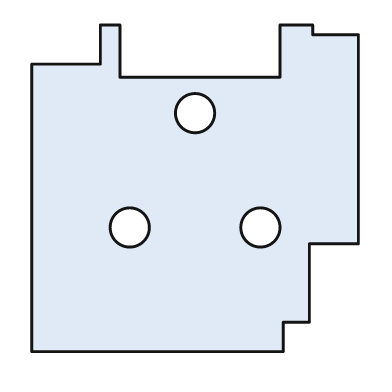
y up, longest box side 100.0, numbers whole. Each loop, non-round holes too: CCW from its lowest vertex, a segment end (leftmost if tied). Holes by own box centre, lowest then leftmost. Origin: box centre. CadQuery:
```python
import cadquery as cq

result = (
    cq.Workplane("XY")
    .moveTo(-50.0, -50.0)
    .lineTo(27.0, -50.0)
    .lineTo(27.0, -41.0)
    .lineTo(35.0, -41.0)
    .lineTo(35.0, -17.0)
    .lineTo(50.0, -17.0)
    .lineTo(50.0, 47.0)
    .lineTo(36.0, 47.0)
    .lineTo(36.0, 50.0)
    .lineTo(26.0, 50.0)
    .lineTo(26.0, 34.0)
    .lineTo(-23.0, 34.0)
    .lineTo(-23.0, 50.0)
    .lineTo(-29.0, 50.0)
    .lineTo(-29.0, 38.0)
    .lineTo(-50.0, 38.0)
    .close()
    .moveTo(-20.0, -12.0)
    .circle(6.0)
    .moveTo(20.0, -12.0)
    .circle(6.0)
    .moveTo(0.0, 23.0)
    .circle(6.0)
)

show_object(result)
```